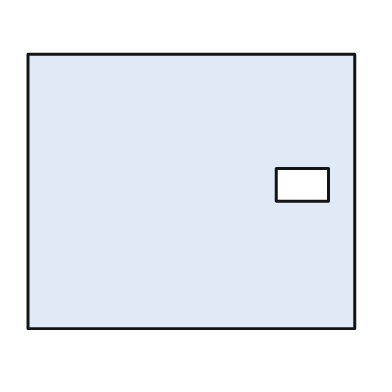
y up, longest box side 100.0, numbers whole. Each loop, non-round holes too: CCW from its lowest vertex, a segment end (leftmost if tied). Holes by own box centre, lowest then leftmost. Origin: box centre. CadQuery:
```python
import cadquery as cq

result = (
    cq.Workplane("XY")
    .moveTo(-50.0, -42.0)
    .lineTo(50.0, -42.0)
    .lineTo(50.0, 42.0)
    .lineTo(-50.0, 42.0)
    .close()
    .moveTo(26.0, -3.0)
    .lineTo(42.0, -3.0)
    .lineTo(42.0, 7.0)
    .lineTo(26.0, 7.0)
    .close()
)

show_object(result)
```